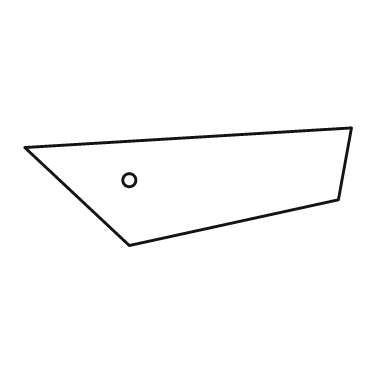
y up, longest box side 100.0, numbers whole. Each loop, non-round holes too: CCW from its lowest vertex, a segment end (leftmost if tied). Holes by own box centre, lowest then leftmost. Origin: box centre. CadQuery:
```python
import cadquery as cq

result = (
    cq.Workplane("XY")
    .moveTo(-18.0, -18.0)
    .lineTo(46.0, -4.0)
    .lineTo(50.0, 18.0)
    .lineTo(-50.0, 12.0)
    .close()
    .moveTo(-18.0, 2.0)
    .circle(2.0)
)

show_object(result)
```